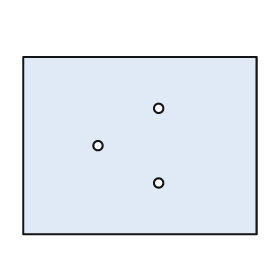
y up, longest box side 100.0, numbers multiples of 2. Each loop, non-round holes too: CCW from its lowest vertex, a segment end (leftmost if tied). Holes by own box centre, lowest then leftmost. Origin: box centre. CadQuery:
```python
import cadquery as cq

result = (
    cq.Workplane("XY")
    .moveTo(-50.0, -38.0)
    .lineTo(50.0, -38.0)
    .lineTo(50.0, 38.0)
    .lineTo(-50.0, 38.0)
    .close()
    .moveTo(8.0, -16.0)
    .circle(2.0)
    .moveTo(-18.0, 0.0)
    .circle(2.0)
    .moveTo(8.0, 16.0)
    .circle(2.0)
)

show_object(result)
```